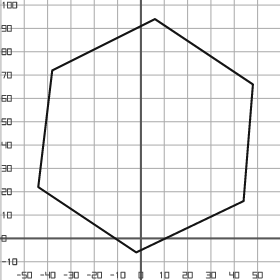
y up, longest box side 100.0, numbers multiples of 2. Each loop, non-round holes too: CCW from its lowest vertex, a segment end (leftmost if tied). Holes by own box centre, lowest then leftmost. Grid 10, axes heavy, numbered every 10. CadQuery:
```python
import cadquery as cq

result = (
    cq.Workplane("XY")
    .moveTo(-2.0, -6.0)
    .lineTo(44.0, 16.0)
    .lineTo(48.0, 66.0)
    .lineTo(6.0, 94.0)
    .lineTo(-38.0, 72.0)
    .lineTo(-44.0, 22.0)
    .close()
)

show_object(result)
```